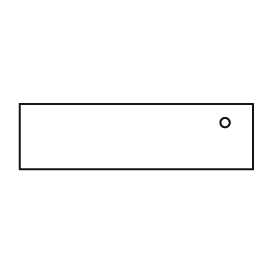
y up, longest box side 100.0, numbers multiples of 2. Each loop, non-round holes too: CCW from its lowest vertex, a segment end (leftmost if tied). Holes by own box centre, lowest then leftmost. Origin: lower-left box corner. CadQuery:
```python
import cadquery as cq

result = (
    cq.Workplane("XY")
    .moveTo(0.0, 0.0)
    .lineTo(100.0, 0.0)
    .lineTo(100.0, 28.0)
    .lineTo(0.0, 28.0)
    .close()
    .moveTo(88.0, 20.0)
    .circle(2.0)
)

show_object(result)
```